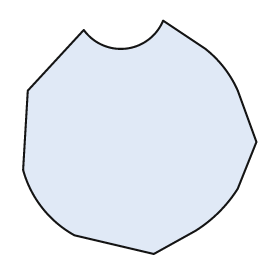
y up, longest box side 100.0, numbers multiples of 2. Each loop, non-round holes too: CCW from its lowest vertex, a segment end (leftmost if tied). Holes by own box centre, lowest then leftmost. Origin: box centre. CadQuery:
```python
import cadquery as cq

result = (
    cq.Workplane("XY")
    .moveTo(6.0, -50.0)
    .lineTo(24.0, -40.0)
    .threePointArc((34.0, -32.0), (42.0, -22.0))
    .lineTo(50.0, -2.0)
    .lineTo(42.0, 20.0)
    .threePointArc((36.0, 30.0), (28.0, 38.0))
    .lineTo(10.0, 50.0)
    .threePointArc((-6.0, 38.0), (-24.0, 46.0))
    .lineTo(-48.0, 20.0)
    .lineTo(-50.0, -14.0)
    .threePointArc((-42.0, -30.0), (-28.0, -42.0))
    .close()
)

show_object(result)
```